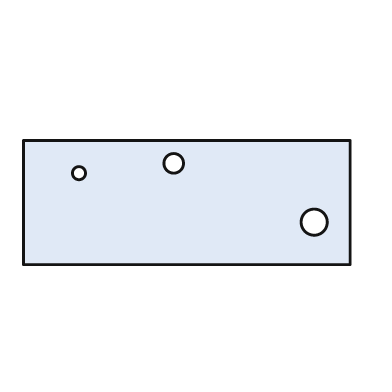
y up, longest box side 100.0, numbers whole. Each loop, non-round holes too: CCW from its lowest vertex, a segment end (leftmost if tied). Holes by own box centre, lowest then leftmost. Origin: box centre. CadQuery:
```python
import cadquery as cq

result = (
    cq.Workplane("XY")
    .moveTo(-50.0, -19.0)
    .lineTo(50.0, -19.0)
    .lineTo(50.0, 19.0)
    .lineTo(-50.0, 19.0)
    .close()
    .moveTo(39.0, -6.0)
    .circle(4.0)
    .moveTo(-33.0, 9.0)
    .circle(2.0)
    .moveTo(-4.0, 12.0)
    .circle(3.0)
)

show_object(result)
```